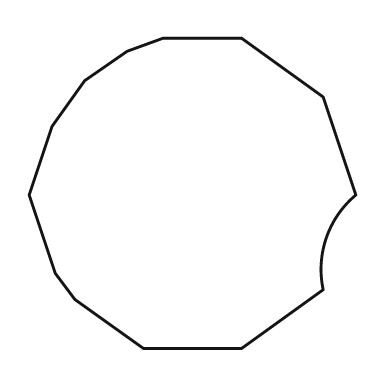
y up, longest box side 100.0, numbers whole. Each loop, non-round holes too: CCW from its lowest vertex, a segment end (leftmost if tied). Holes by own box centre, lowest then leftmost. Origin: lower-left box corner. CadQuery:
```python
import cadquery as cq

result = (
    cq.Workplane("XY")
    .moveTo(35.0, 0.0)
    .lineTo(65.0, 0.0)
    .lineTo(90.0, 18.0)
    .threePointArc((91.0, 34.0), (100.0, 47.0))
    .lineTo(90.0, 77.0)
    .lineTo(65.0, 95.0)
    .lineTo(41.0, 95.0)
    .lineTo(30.0, 91.0)
    .lineTo(17.0, 82.0)
    .lineTo(7.0, 68.0)
    .lineTo(0.0, 47.0)
    .lineTo(8.0, 23.0)
    .lineTo(14.0, 15.0)
    .close()
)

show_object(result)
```